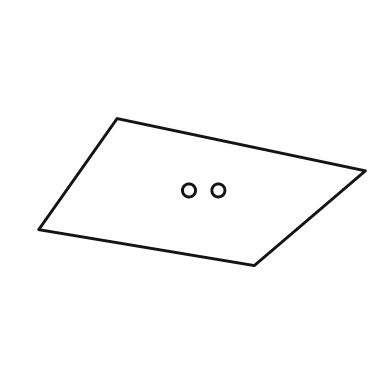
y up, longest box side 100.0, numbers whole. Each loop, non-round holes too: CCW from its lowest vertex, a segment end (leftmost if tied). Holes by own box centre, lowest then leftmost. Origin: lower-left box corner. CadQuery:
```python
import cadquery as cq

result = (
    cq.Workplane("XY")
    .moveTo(66.0, 0.0)
    .lineTo(100.0, 29.0)
    .lineTo(24.0, 45.0)
    .lineTo(0.0, 11.0)
    .close()
    .moveTo(46.0, 23.0)
    .circle(2.0)
    .moveTo(55.0, 23.0)
    .circle(2.0)
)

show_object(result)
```